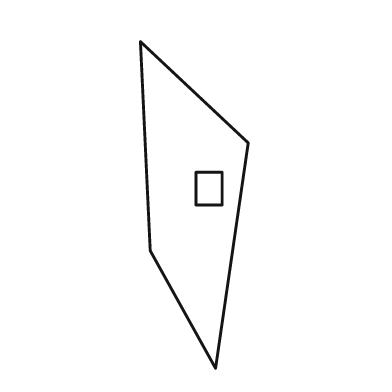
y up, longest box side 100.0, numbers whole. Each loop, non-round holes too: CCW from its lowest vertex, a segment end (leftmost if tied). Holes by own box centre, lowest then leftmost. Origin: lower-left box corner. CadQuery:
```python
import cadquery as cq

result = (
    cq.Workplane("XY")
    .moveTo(23.0, 0.0)
    .lineTo(33.0, 69.0)
    .lineTo(0.0, 100.0)
    .lineTo(3.0, 36.0)
    .close()
    .moveTo(17.0, 50.0)
    .lineTo(25.0, 50.0)
    .lineTo(25.0, 60.0)
    .lineTo(17.0, 60.0)
    .close()
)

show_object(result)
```